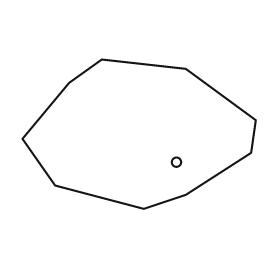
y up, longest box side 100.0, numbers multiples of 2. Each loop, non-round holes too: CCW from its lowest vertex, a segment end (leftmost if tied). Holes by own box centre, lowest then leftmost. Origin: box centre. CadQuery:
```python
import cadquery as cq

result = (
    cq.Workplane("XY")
    .moveTo(2.0, -32.0)
    .lineTo(20.0, -26.0)
    .lineTo(48.0, -8.0)
    .lineTo(50.0, 6.0)
    .lineTo(20.0, 28.0)
    .lineTo(-16.0, 32.0)
    .lineTo(-30.0, 22.0)
    .lineTo(-50.0, -2.0)
    .lineTo(-36.0, -22.0)
    .close()
    .moveTo(16.0, -12.0)
    .circle(2.0)
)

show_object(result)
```